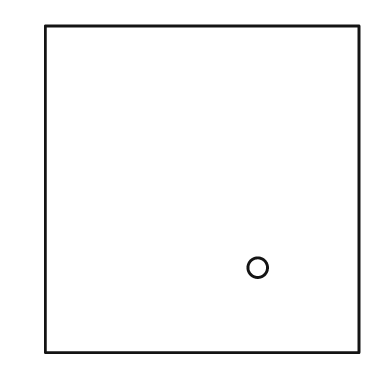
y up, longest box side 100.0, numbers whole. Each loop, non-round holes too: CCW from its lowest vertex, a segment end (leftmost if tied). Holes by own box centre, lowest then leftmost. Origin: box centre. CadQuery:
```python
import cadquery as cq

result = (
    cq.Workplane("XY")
    .moveTo(-48.0, -50.0)
    .lineTo(48.0, -50.0)
    .lineTo(48.0, 50.0)
    .lineTo(-48.0, 50.0)
    .close()
    .moveTo(17.0, -24.0)
    .circle(3.0)
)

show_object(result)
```